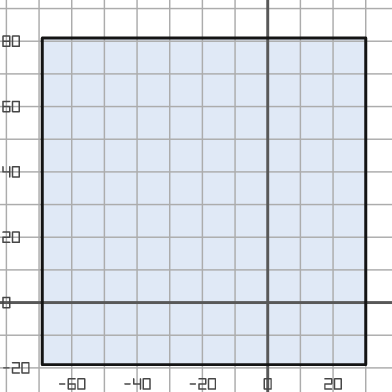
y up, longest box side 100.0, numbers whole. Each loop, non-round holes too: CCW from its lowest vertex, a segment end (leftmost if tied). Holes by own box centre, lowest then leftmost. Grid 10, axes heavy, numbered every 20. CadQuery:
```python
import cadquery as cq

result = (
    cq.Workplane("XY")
    .moveTo(-69.0, -19.0)
    .lineTo(30.0, -19.0)
    .lineTo(30.0, 81.0)
    .lineTo(-69.0, 81.0)
    .close()
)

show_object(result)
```